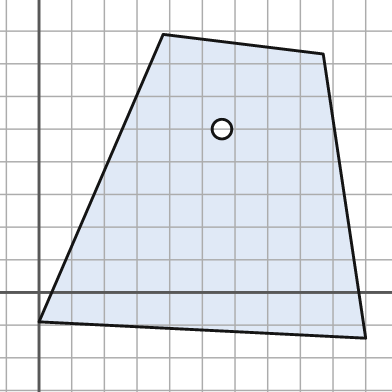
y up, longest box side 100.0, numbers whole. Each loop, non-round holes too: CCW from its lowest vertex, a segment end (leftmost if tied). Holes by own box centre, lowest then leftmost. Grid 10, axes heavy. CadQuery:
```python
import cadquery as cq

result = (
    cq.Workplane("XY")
    .moveTo(100.0, -14.0)
    .lineTo(87.0, 73.0)
    .lineTo(38.0, 79.0)
    .lineTo(0.0, -9.0)
    .close()
    .moveTo(56.0, 50.0)
    .circle(3.0)
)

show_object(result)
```